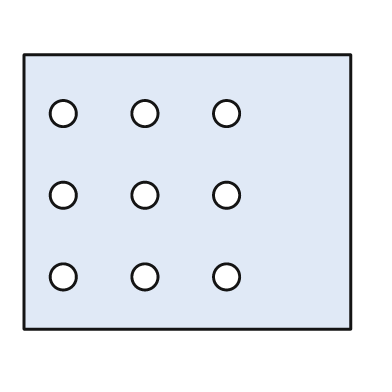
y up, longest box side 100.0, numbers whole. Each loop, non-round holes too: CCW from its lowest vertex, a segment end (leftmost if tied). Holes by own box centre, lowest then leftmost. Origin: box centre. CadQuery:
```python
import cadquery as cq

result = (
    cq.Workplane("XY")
    .moveTo(-50.0, -42.0)
    .lineTo(50.0, -42.0)
    .lineTo(50.0, 42.0)
    .lineTo(-50.0, 42.0)
    .close()
    .moveTo(-38.0, -26.0)
    .circle(4.0)
    .moveTo(-13.0, -26.0)
    .circle(4.0)
    .moveTo(12.0, -26.0)
    .circle(4.0)
    .moveTo(-38.0, -1.0)
    .circle(4.0)
    .moveTo(-13.0, -1.0)
    .circle(4.0)
    .moveTo(12.0, -1.0)
    .circle(4.0)
    .moveTo(-38.0, 24.0)
    .circle(4.0)
    .moveTo(-13.0, 24.0)
    .circle(4.0)
    .moveTo(12.0, 24.0)
    .circle(4.0)
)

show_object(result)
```